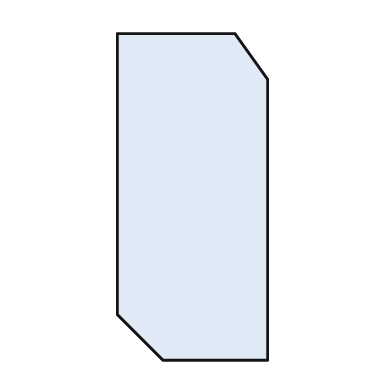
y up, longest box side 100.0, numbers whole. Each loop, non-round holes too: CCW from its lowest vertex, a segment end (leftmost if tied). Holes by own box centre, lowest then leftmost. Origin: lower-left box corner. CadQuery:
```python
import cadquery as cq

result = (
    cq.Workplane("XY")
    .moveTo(14.0, 0.0)
    .lineTo(46.0, 0.0)
    .lineTo(46.0, 86.0)
    .lineTo(36.0, 100.0)
    .lineTo(0.0, 100.0)
    .lineTo(0.0, 14.0)
    .close()
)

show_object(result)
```